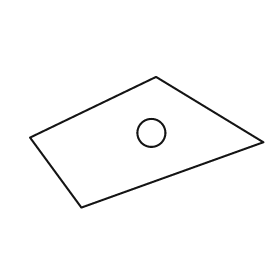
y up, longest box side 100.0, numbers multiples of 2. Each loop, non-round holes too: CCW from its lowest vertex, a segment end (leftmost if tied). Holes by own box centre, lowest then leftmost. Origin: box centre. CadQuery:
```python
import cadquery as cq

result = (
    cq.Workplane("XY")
    .moveTo(-28.0, -28.0)
    .lineTo(50.0, 0.0)
    .lineTo(4.0, 28.0)
    .lineTo(-50.0, 2.0)
    .close()
    .moveTo(2.0, 4.0)
    .circle(6.0)
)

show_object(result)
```